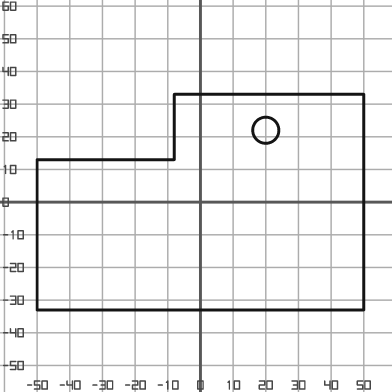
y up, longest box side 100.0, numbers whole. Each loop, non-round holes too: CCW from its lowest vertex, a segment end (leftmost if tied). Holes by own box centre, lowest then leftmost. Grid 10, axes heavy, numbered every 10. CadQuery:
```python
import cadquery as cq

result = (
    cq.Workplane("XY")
    .moveTo(-50.0, -33.0)
    .lineTo(50.0, -33.0)
    .lineTo(50.0, 33.0)
    .lineTo(-8.0, 33.0)
    .lineTo(-8.0, 13.0)
    .lineTo(-50.0, 13.0)
    .close()
    .moveTo(20.0, 22.0)
    .circle(4.0)
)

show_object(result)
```